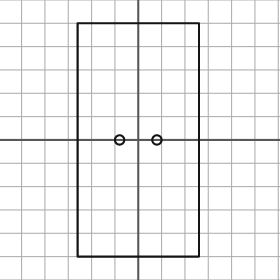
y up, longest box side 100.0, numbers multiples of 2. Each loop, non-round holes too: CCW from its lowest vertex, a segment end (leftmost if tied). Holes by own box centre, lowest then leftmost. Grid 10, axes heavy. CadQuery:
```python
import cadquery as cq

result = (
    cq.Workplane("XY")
    .moveTo(-26.0, -50.0)
    .lineTo(26.0, -50.0)
    .lineTo(26.0, 50.0)
    .lineTo(-26.0, 50.0)
    .close()
    .moveTo(-8.0, 0.0)
    .circle(2.0)
    .moveTo(8.0, 0.0)
    .circle(2.0)
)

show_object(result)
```